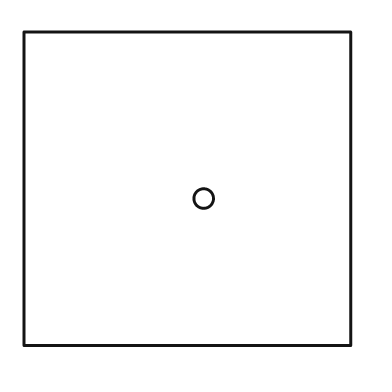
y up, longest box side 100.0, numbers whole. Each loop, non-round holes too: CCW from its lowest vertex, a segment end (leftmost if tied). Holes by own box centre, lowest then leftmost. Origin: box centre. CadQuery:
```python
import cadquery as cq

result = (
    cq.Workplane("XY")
    .moveTo(-50.0, -48.0)
    .lineTo(50.0, -48.0)
    .lineTo(50.0, 48.0)
    .lineTo(-50.0, 48.0)
    .close()
    .moveTo(5.0, -3.0)
    .circle(3.0)
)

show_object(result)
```